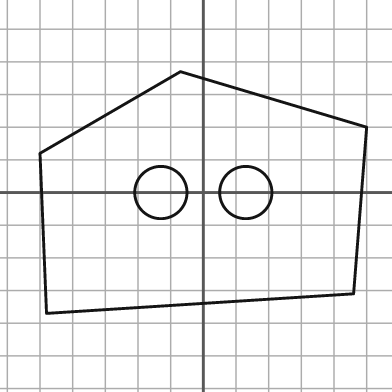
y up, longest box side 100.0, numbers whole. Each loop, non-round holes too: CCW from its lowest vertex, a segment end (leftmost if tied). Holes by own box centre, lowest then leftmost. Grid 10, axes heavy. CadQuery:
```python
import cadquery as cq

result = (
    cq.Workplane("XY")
    .moveTo(-48.0, -37.0)
    .lineTo(46.0, -31.0)
    .lineTo(50.0, 20.0)
    .lineTo(-7.0, 37.0)
    .lineTo(-50.0, 12.0)
    .close()
    .moveTo(-13.0, 0.0)
    .circle(8.0)
    .moveTo(13.0, 0.0)
    .circle(8.0)
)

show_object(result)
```